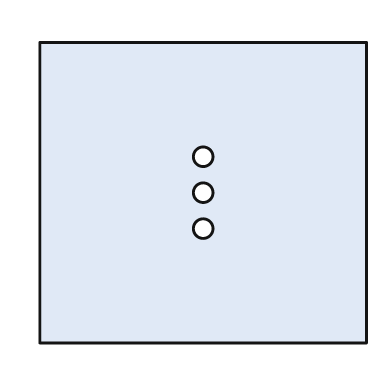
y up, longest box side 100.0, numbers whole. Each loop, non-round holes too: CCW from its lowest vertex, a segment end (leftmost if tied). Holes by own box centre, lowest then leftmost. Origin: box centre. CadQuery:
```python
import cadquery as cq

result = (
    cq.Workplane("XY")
    .moveTo(-50.0, -46.0)
    .lineTo(50.0, -46.0)
    .lineTo(50.0, 46.0)
    .lineTo(-50.0, 46.0)
    .close()
    .moveTo(0.0, -11.0)
    .circle(3.0)
    .moveTo(0.0, 0.0)
    .circle(3.0)
    .moveTo(0.0, 11.0)
    .circle(3.0)
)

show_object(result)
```